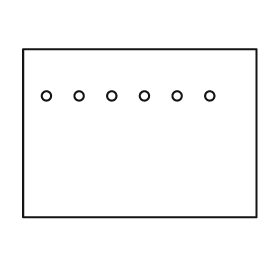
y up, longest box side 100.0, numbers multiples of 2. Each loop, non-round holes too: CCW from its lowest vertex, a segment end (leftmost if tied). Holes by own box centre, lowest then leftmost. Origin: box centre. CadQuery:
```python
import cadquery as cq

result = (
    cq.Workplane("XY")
    .moveTo(-50.0, -36.0)
    .lineTo(50.0, -36.0)
    .lineTo(50.0, 36.0)
    .lineTo(-50.0, 36.0)
    .close()
    .moveTo(-40.0, 16.0)
    .circle(2.0)
    .moveTo(-26.0, 16.0)
    .circle(2.0)
    .moveTo(-12.0, 16.0)
    .circle(2.0)
    .moveTo(2.0, 16.0)
    .circle(2.0)
    .moveTo(16.0, 16.0)
    .circle(2.0)
    .moveTo(30.0, 16.0)
    .circle(2.0)
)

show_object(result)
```